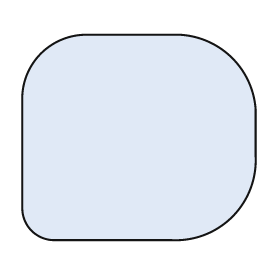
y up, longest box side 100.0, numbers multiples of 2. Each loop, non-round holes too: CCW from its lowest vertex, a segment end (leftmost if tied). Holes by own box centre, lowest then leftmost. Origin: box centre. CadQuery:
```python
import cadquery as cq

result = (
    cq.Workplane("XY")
    .moveTo(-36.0, -44.0)
    .lineTo(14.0, -44.0)
    .threePointArc((40.0, -34.0), (50.0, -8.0))
    .lineTo(50.0, 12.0)
    .threePointArc((40.0, 34.0), (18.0, 44.0))
    .lineTo(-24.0, 44.0)
    .threePointArc((-42.0, 36.0), (-50.0, 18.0))
    .lineTo(-50.0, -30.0)
    .threePointArc((-46.0, -40.0), (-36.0, -44.0))
    .close()
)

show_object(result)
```